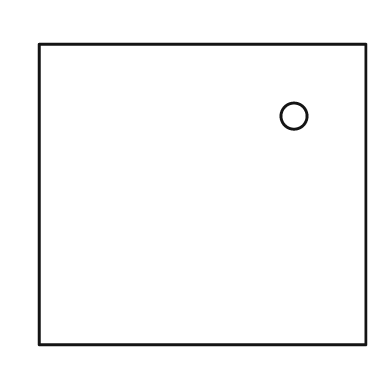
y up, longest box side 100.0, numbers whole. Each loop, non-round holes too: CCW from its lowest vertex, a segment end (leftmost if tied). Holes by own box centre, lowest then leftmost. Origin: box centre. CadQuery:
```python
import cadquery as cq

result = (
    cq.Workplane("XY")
    .moveTo(-50.0, -46.0)
    .lineTo(50.0, -46.0)
    .lineTo(50.0, 46.0)
    .lineTo(-50.0, 46.0)
    .close()
    .moveTo(28.0, 24.0)
    .circle(4.0)
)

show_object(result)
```